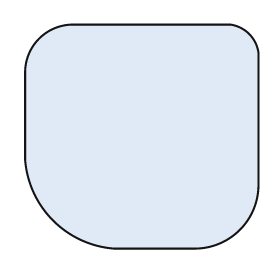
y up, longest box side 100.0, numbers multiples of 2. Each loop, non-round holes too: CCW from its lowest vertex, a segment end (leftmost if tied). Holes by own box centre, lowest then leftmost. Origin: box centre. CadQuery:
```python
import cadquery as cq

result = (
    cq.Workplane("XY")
    .moveTo(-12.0, -48.0)
    .lineTo(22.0, -48.0)
    .threePointArc((42.0, -40.0), (50.0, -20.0))
    .lineTo(50.0, 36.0)
    .threePointArc((46.0, 44.0), (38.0, 48.0))
    .lineTo(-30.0, 48.0)
    .threePointArc((-44.0, 42.0), (-50.0, 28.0))
    .lineTo(-50.0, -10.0)
    .threePointArc((-38.0, -36.0), (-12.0, -48.0))
    .close()
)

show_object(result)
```